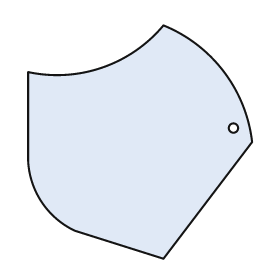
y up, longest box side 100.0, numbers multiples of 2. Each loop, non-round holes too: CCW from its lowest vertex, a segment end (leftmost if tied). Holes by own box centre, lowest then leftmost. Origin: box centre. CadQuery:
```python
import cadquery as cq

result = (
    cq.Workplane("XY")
    .moveTo(10.0, -50.0)
    .lineTo(48.0, 0.0)
    .threePointArc((36.0, 30.0), (10.0, 50.0))
    .threePointArc((-16.0, 32.0), (-48.0, 30.0))
    .lineTo(-48.0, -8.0)
    .threePointArc((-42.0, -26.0), (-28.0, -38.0))
    .close()
    .moveTo(40.0, 6.0)
    .circle(2.0)
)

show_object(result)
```